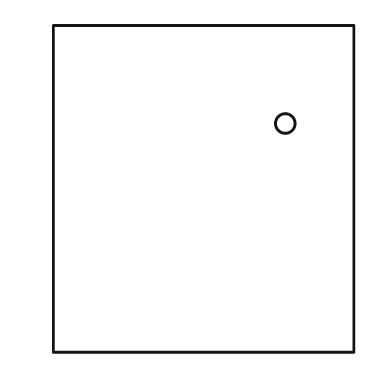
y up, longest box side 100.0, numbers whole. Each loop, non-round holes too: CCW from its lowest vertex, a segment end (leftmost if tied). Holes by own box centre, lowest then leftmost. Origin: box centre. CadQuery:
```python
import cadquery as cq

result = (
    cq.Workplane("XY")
    .moveTo(-46.0, -50.0)
    .lineTo(46.0, -50.0)
    .lineTo(46.0, 50.0)
    .lineTo(-46.0, 50.0)
    .close()
    .moveTo(25.0, 20.0)
    .circle(3.0)
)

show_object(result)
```